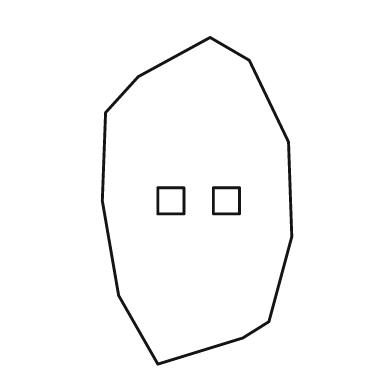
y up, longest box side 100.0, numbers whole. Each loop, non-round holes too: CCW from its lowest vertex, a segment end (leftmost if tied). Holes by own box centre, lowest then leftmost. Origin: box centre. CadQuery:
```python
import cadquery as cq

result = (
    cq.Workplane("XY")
    .moveTo(-12.0, -50.0)
    .lineTo(14.0, -42.0)
    .lineTo(22.0, -37.0)
    .lineTo(29.0, -11.0)
    .lineTo(28.0, 18.0)
    .lineTo(16.0, 43.0)
    .lineTo(4.0, 50.0)
    .lineTo(-18.0, 38.0)
    .lineTo(-28.0, 27.0)
    .lineTo(-29.0, 0.0)
    .lineTo(-24.0, -29.0)
    .close()
    .moveTo(-12.0, -4.0)
    .lineTo(-4.0, -4.0)
    .lineTo(-4.0, 4.0)
    .lineTo(-12.0, 4.0)
    .close()
    .moveTo(5.0, -4.0)
    .lineTo(13.0, -4.0)
    .lineTo(13.0, 4.0)
    .lineTo(5.0, 4.0)
    .close()
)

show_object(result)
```